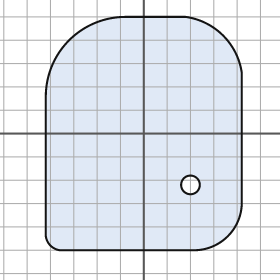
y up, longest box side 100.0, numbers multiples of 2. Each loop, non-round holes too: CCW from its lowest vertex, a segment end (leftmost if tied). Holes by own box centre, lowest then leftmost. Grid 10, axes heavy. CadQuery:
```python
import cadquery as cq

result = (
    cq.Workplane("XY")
    .moveTo(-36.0, -50.0)
    .lineTo(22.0, -50.0)
    .threePointArc((36.0, -44.0), (42.0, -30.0))
    .lineTo(42.0, 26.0)
    .threePointArc((34.0, 42.0), (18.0, 50.0))
    .lineTo(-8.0, 50.0)
    .threePointArc((-32.0, 40.0), (-42.0, 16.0))
    .lineTo(-42.0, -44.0)
    .threePointArc((-40.0, -48.0), (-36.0, -50.0))
    .close()
    .moveTo(20.0, -22.0)
    .circle(4.0)
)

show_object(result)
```